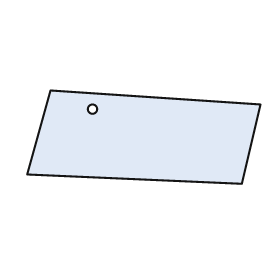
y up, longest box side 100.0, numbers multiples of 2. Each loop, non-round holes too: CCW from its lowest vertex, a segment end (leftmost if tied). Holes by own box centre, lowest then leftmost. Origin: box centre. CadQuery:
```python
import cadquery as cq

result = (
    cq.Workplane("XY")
    .moveTo(42.0, -20.0)
    .lineTo(50.0, 14.0)
    .lineTo(-40.0, 20.0)
    .lineTo(-50.0, -16.0)
    .close()
    .moveTo(-22.0, 12.0)
    .circle(2.0)
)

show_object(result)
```